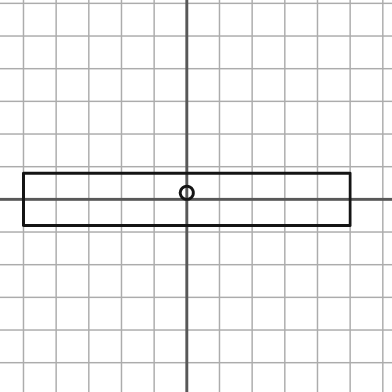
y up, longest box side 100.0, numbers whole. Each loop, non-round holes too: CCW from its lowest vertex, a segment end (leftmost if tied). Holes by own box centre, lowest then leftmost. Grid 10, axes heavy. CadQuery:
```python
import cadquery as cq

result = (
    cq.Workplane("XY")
    .moveTo(-50.0, -8.0)
    .lineTo(50.0, -8.0)
    .lineTo(50.0, 8.0)
    .lineTo(-50.0, 8.0)
    .close()
    .moveTo(0.0, 2.0)
    .circle(2.0)
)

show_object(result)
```